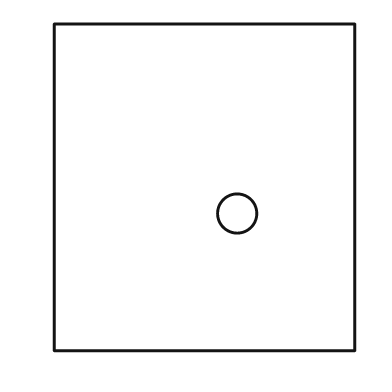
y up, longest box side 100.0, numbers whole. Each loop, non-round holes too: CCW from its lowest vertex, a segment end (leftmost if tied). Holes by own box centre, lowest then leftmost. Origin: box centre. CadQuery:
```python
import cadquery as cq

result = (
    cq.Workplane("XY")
    .moveTo(-46.0, -50.0)
    .lineTo(46.0, -50.0)
    .lineTo(46.0, 50.0)
    .lineTo(-46.0, 50.0)
    .close()
    .moveTo(10.0, -8.0)
    .circle(6.0)
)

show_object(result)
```